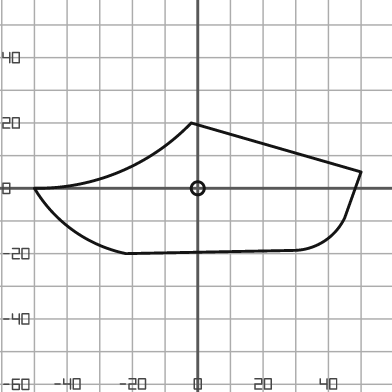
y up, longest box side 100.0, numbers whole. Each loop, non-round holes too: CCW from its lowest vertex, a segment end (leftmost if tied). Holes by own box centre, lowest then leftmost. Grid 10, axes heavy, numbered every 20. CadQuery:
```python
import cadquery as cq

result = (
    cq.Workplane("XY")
    .moveTo(-22.0, -20.0)
    .lineTo(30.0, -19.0)
    .threePointArc((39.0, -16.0), (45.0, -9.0))
    .lineTo(50.0, 5.0)
    .lineTo(-2.0, 20.0)
    .threePointArc((-24.0, 5.0), (-50.0, 0.0))
    .threePointArc((-38.0, -13.0), (-22.0, -20.0))
    .close()
    .moveTo(0.0, 0.0)
    .circle(2.0)
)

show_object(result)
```